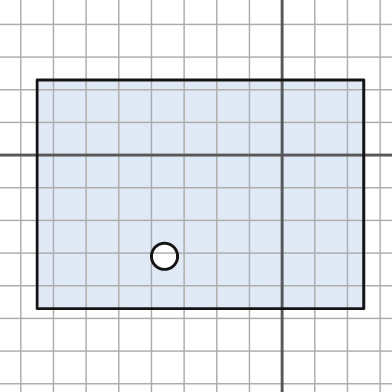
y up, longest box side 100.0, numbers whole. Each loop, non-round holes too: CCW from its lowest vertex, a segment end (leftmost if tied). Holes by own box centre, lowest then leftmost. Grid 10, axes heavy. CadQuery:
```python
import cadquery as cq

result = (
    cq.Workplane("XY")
    .moveTo(-75.0, -47.0)
    .lineTo(25.0, -47.0)
    .lineTo(25.0, 23.0)
    .lineTo(-75.0, 23.0)
    .close()
    .moveTo(-36.0, -31.0)
    .circle(4.0)
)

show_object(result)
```